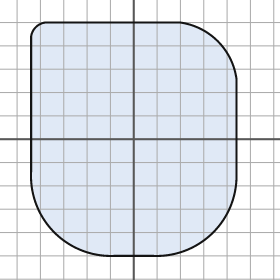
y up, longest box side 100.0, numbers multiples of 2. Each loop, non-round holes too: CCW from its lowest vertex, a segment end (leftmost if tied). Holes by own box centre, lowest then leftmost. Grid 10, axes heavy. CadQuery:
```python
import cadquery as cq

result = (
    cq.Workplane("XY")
    .moveTo(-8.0, -50.0)
    .lineTo(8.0, -50.0)
    .threePointArc((34.0, -40.0), (44.0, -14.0))
    .lineTo(44.0, 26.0)
    .threePointArc((36.0, 42.0), (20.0, 50.0))
    .lineTo(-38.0, 50.0)
    .threePointArc((-42.0, 48.0), (-44.0, 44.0))
    .lineTo(-44.0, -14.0)
    .threePointArc((-34.0, -40.0), (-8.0, -50.0))
    .close()
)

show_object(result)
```